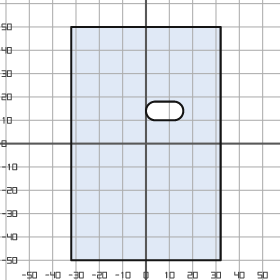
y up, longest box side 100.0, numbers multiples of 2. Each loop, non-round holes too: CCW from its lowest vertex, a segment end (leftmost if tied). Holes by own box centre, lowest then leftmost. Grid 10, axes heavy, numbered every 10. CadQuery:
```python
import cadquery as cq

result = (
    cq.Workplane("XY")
    .moveTo(-32.0, -50.0)
    .lineTo(32.0, -50.0)
    .lineTo(32.0, 50.0)
    .lineTo(-32.0, 50.0)
    .close()
    .moveTo(4.0, 10.0)
    .lineTo(12.0, 10.0)
    .threePointArc((16.0, 14.0), (12.0, 18.0))
    .lineTo(4.0, 18.0)
    .threePointArc((0.0, 14.0), (4.0, 10.0))
    .close()
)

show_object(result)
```